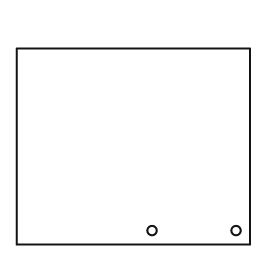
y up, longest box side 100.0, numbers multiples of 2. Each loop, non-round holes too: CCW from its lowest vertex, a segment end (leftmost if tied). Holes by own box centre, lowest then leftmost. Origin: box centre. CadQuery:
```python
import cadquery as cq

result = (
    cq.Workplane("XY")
    .moveTo(-50.0, -42.0)
    .lineTo(50.0, -42.0)
    .lineTo(50.0, 42.0)
    .lineTo(-50.0, 42.0)
    .close()
    .moveTo(8.0, -36.0)
    .circle(2.0)
    .moveTo(44.0, -36.0)
    .circle(2.0)
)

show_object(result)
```